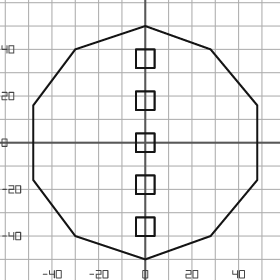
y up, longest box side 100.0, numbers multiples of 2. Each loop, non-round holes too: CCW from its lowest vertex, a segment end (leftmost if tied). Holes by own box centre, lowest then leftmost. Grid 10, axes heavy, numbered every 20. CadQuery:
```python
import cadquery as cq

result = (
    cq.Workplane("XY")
    .moveTo(0.0, -50.0)
    .lineTo(28.0, -40.0)
    .lineTo(48.0, -16.0)
    .lineTo(48.0, 16.0)
    .lineTo(28.0, 40.0)
    .lineTo(0.0, 50.0)
    .lineTo(-30.0, 40.0)
    .lineTo(-48.0, 16.0)
    .lineTo(-48.0, -16.0)
    .lineTo(-30.0, -40.0)
    .close()
    .moveTo(-4.0, -40.0)
    .lineTo(4.0, -40.0)
    .lineTo(4.0, -32.0)
    .lineTo(-4.0, -32.0)
    .close()
    .moveTo(-4.0, -22.0)
    .lineTo(4.0, -22.0)
    .lineTo(4.0, -14.0)
    .lineTo(-4.0, -14.0)
    .close()
    .moveTo(-4.0, -4.0)
    .lineTo(4.0, -4.0)
    .lineTo(4.0, 4.0)
    .lineTo(-4.0, 4.0)
    .close()
    .moveTo(-4.0, 14.0)
    .lineTo(4.0, 14.0)
    .lineTo(4.0, 22.0)
    .lineTo(-4.0, 22.0)
    .close()
    .moveTo(-4.0, 32.0)
    .lineTo(4.0, 32.0)
    .lineTo(4.0, 40.0)
    .lineTo(-4.0, 40.0)
    .close()
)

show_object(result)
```